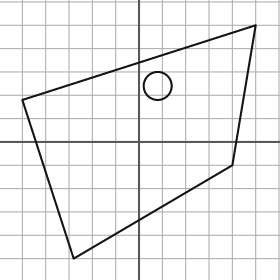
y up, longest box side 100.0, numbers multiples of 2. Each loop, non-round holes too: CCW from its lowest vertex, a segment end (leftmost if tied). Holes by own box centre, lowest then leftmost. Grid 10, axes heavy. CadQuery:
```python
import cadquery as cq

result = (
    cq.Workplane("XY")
    .moveTo(-28.0, -50.0)
    .lineTo(40.0, -10.0)
    .lineTo(50.0, 50.0)
    .lineTo(-50.0, 18.0)
    .close()
    .moveTo(8.0, 24.0)
    .circle(6.0)
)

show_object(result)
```